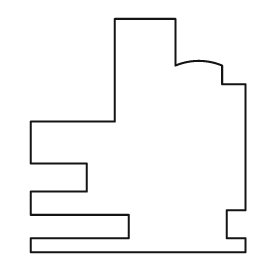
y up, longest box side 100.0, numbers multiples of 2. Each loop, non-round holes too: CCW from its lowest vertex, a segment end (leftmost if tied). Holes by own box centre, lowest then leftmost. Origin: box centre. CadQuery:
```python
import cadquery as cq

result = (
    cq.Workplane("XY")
    .moveTo(-46.0, -50.0)
    .lineTo(46.0, -50.0)
    .lineTo(46.0, -44.0)
    .lineTo(38.0, -44.0)
    .lineTo(38.0, -32.0)
    .lineTo(46.0, -32.0)
    .lineTo(46.0, 22.0)
    .lineTo(36.0, 22.0)
    .lineTo(36.0, 30.0)
    .threePointArc((26.0, 32.0), (16.0, 30.0))
    .lineTo(16.0, 50.0)
    .lineTo(-10.0, 50.0)
    .lineTo(-10.0, 6.0)
    .lineTo(-46.0, 6.0)
    .lineTo(-46.0, -12.0)
    .lineTo(-22.0, -12.0)
    .lineTo(-22.0, -24.0)
    .lineTo(-46.0, -24.0)
    .lineTo(-46.0, -34.0)
    .lineTo(-4.0, -34.0)
    .lineTo(-4.0, -44.0)
    .lineTo(-46.0, -44.0)
    .close()
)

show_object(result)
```